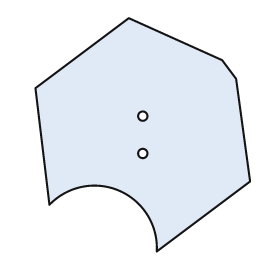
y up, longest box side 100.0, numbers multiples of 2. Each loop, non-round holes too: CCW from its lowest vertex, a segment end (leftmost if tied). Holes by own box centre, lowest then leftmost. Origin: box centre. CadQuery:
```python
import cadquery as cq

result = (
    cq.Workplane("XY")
    .moveTo(6.0, -50.0)
    .lineTo(46.0, -20.0)
    .lineTo(40.0, 24.0)
    .lineTo(34.0, 32.0)
    .lineTo(-6.0, 50.0)
    .lineTo(-46.0, 20.0)
    .lineTo(-40.0, -30.0)
    .threePointArc((-10.0, -24.0), (6.0, -50.0))
    .close()
    .moveTo(0.0, -8.0)
    .circle(2.0)
    .moveTo(0.0, 8.0)
    .circle(2.0)
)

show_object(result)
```